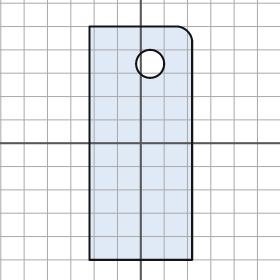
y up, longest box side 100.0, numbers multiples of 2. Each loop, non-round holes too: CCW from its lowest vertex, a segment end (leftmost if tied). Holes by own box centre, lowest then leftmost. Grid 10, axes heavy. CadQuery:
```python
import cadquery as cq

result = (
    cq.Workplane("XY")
    .moveTo(-22.0, -50.0)
    .lineTo(22.0, -50.0)
    .lineTo(22.0, 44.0)
    .threePointArc((20.0, 48.0), (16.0, 50.0))
    .lineTo(-22.0, 50.0)
    .close()
    .moveTo(4.0, 34.0)
    .circle(6.0)
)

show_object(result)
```